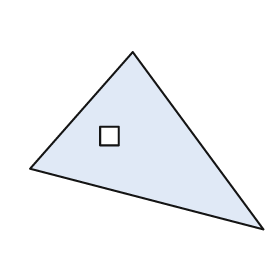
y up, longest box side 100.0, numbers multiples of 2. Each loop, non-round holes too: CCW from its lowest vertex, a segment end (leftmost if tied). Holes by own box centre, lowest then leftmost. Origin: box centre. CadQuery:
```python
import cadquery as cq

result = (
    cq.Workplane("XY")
    .moveTo(50.0, -38.0)
    .lineTo(-6.0, 38.0)
    .lineTo(-50.0, -12.0)
    .close()
    .moveTo(-20.0, -2.0)
    .lineTo(-12.0, -2.0)
    .lineTo(-12.0, 6.0)
    .lineTo(-20.0, 6.0)
    .close()
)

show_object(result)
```